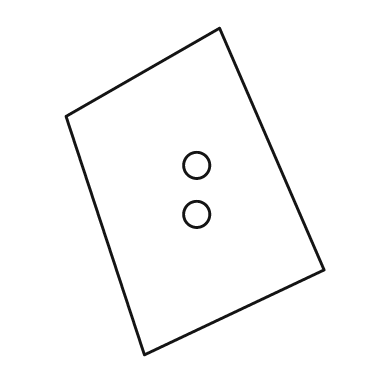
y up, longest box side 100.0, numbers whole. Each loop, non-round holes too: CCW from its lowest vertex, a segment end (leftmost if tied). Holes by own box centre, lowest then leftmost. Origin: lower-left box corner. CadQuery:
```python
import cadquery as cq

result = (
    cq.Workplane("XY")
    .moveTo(24.0, 0.0)
    .lineTo(79.0, 26.0)
    .lineTo(47.0, 100.0)
    .lineTo(0.0, 73.0)
    .close()
    .moveTo(40.0, 43.0)
    .circle(4.0)
    .moveTo(40.0, 58.0)
    .circle(4.0)
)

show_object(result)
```